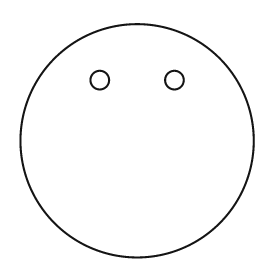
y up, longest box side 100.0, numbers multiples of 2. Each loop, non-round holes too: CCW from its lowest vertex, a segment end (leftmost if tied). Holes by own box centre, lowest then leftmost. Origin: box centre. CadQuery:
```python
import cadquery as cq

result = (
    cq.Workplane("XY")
    .moveTo(0.0, 0.0)
    .circle(50.0)
    .moveTo(-16.0, 26.0)
    .circle(4.0)
    .moveTo(16.0, 26.0)
    .circle(4.0)
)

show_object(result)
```